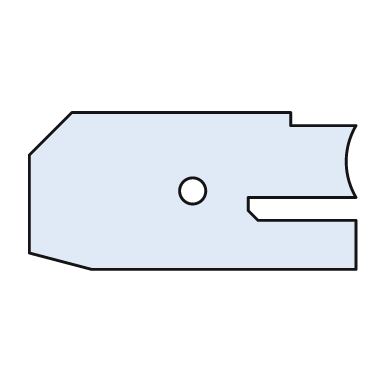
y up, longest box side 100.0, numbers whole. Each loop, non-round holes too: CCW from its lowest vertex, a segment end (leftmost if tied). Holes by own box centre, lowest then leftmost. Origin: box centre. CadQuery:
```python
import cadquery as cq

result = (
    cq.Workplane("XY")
    .moveTo(-31.0, -24.0)
    .lineTo(50.0, -24.0)
    .lineTo(50.0, -9.0)
    .lineTo(20.0, -9.0)
    .lineTo(17.0, -6.0)
    .lineTo(17.0, -2.0)
    .lineTo(50.0, -2.0)
    .threePointArc((47.0, 9.0), (50.0, 20.0))
    .lineTo(30.0, 20.0)
    .lineTo(30.0, 24.0)
    .lineTo(-37.0, 24.0)
    .lineTo(-50.0, 11.0)
    .lineTo(-50.0, -19.0)
    .close()
    .moveTo(0.0, 0.0)
    .circle(4.0)
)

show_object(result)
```